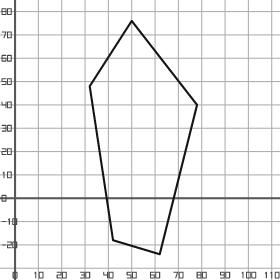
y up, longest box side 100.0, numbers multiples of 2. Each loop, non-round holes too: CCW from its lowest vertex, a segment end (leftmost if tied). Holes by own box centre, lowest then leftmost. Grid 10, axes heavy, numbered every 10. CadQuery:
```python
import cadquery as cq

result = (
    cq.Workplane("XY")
    .moveTo(62.0, -24.0)
    .lineTo(78.0, 40.0)
    .lineTo(50.0, 76.0)
    .lineTo(32.0, 48.0)
    .lineTo(42.0, -18.0)
    .close()
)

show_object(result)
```